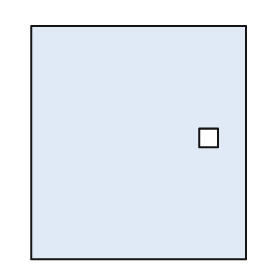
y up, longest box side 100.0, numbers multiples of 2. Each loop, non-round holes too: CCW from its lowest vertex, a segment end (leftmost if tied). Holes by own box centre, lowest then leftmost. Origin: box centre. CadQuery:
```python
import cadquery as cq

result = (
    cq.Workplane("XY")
    .moveTo(-46.0, -50.0)
    .lineTo(46.0, -50.0)
    .lineTo(46.0, 50.0)
    .lineTo(-46.0, 50.0)
    .close()
    .moveTo(26.0, -2.0)
    .lineTo(34.0, -2.0)
    .lineTo(34.0, 6.0)
    .lineTo(26.0, 6.0)
    .close()
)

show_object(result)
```